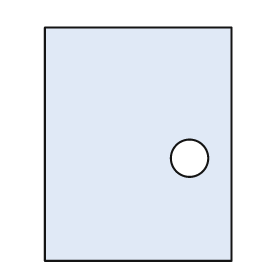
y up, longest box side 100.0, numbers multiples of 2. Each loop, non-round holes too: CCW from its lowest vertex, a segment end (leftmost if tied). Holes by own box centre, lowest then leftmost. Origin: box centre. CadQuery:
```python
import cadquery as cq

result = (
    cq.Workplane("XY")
    .moveTo(-40.0, -50.0)
    .lineTo(40.0, -50.0)
    .lineTo(40.0, 50.0)
    .lineTo(-40.0, 50.0)
    .close()
    .moveTo(22.0, -6.0)
    .circle(8.0)
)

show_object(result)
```